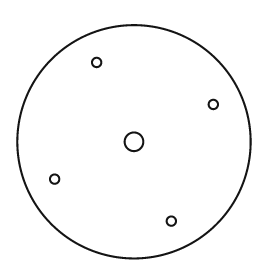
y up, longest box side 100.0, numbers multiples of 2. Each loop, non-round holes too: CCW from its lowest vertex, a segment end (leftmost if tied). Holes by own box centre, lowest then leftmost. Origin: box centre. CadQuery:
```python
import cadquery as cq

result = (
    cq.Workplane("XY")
    .moveTo(0.0, 0.0)
    .circle(50.0)
    .moveTo(16.0, -34.0)
    .circle(2.0)
    .moveTo(-34.0, -16.0)
    .circle(2.0)
    .moveTo(0.0, 0.0)
    .circle(4.0)
    .moveTo(34.0, 16.0)
    .circle(2.0)
    .moveTo(-16.0, 34.0)
    .circle(2.0)
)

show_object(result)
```